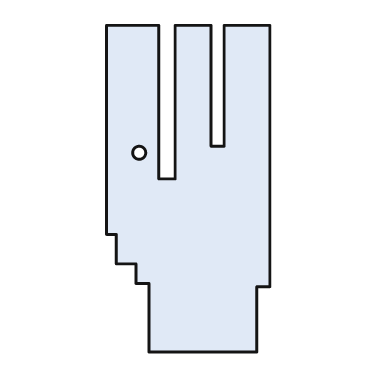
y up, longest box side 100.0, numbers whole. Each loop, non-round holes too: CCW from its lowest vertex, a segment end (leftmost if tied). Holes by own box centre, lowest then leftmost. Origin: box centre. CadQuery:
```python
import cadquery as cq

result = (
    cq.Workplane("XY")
    .moveTo(-12.0, -50.0)
    .lineTo(21.0, -50.0)
    .lineTo(21.0, -30.0)
    .lineTo(25.0, -30.0)
    .lineTo(25.0, 50.0)
    .lineTo(11.0, 50.0)
    .lineTo(11.0, 13.0)
    .lineTo(7.0, 13.0)
    .lineTo(7.0, 50.0)
    .lineTo(-4.0, 50.0)
    .lineTo(-4.0, 3.0)
    .lineTo(-9.0, 3.0)
    .lineTo(-9.0, 50.0)
    .lineTo(-25.0, 50.0)
    .lineTo(-25.0, -14.0)
    .lineTo(-22.0, -14.0)
    .lineTo(-22.0, -23.0)
    .lineTo(-16.0, -23.0)
    .lineTo(-16.0, -29.0)
    .lineTo(-12.0, -29.0)
    .close()
    .moveTo(-15.0, 11.0)
    .circle(2.0)
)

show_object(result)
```